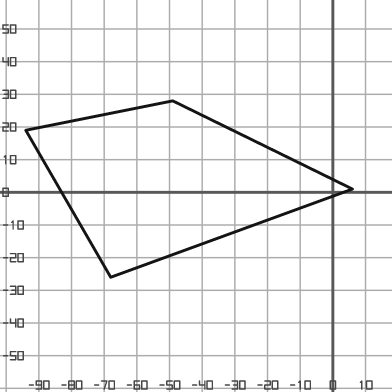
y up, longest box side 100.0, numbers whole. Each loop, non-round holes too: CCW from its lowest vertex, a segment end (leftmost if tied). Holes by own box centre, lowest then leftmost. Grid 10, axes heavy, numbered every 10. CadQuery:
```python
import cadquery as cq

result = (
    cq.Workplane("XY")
    .moveTo(-68.0, -26.0)
    .lineTo(6.0, 1.0)
    .lineTo(-49.0, 28.0)
    .lineTo(-94.0, 19.0)
    .close()
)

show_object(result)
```